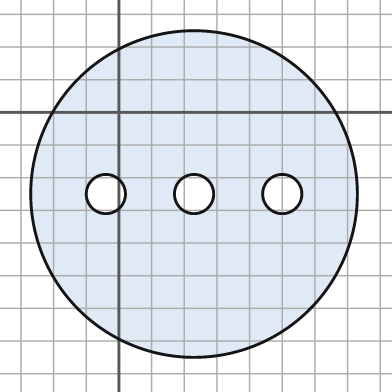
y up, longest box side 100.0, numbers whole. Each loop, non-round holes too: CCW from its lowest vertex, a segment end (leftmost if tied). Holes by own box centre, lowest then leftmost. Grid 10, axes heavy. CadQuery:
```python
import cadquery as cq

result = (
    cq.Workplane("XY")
    .moveTo(23.0, -25.0)
    .circle(50.0)
    .moveTo(-4.0, -25.0)
    .circle(6.0)
    .moveTo(23.0, -25.0)
    .circle(6.0)
    .moveTo(50.0, -25.0)
    .circle(6.0)
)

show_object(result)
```